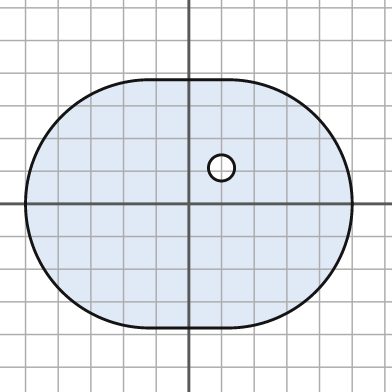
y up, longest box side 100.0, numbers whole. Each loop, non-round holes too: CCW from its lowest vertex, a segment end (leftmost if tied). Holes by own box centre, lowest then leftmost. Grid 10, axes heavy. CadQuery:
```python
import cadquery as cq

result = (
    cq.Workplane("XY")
    .moveTo(-12.0, -38.0)
    .lineTo(12.0, -38.0)
    .threePointArc((50.0, 0.0), (12.0, 38.0))
    .lineTo(-12.0, 38.0)
    .threePointArc((-50.0, 0.0), (-12.0, -38.0))
    .close()
    .moveTo(10.0, 11.0)
    .circle(4.0)
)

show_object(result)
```